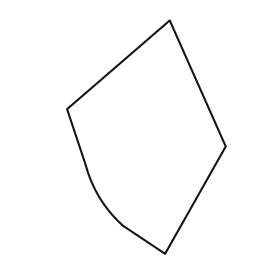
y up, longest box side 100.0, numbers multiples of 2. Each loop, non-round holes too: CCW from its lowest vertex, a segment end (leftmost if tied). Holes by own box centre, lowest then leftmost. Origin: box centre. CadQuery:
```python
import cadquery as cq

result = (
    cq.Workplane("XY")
    .moveTo(8.0, -50.0)
    .lineTo(34.0, -4.0)
    .lineTo(10.0, 50.0)
    .lineTo(-34.0, 12.0)
    .lineTo(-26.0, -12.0)
    .threePointArc((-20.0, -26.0), (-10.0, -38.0))
    .close()
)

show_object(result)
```